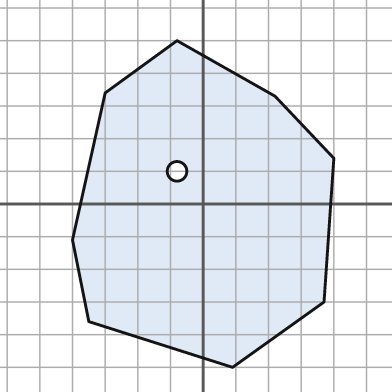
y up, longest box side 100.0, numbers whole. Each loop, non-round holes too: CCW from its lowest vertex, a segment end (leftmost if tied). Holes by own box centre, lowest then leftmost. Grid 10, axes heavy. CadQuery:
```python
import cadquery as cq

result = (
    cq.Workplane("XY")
    .moveTo(9.0, -50.0)
    .lineTo(37.0, -30.0)
    .lineTo(40.0, 14.0)
    .lineTo(22.0, 33.0)
    .lineTo(-8.0, 50.0)
    .lineTo(-30.0, 34.0)
    .lineTo(-40.0, -11.0)
    .lineTo(-35.0, -36.0)
    .close()
    .moveTo(-8.0, 10.0)
    .circle(3.0)
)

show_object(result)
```